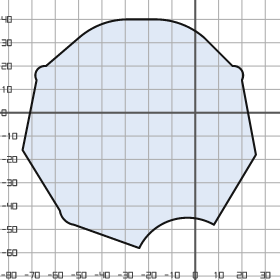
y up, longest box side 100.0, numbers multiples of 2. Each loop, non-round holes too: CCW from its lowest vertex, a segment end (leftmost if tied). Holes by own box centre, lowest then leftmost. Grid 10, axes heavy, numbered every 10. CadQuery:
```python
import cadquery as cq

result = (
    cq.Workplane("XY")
    .moveTo(-24.0, -58.0)
    .threePointArc((-10.0, -46.0), (8.0, -48.0))
    .lineTo(26.0, -18.0)
    .lineTo(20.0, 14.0)
    .threePointArc((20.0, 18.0), (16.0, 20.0))
    .lineTo(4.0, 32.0)
    .threePointArc((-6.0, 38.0), (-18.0, 40.0))
    .lineTo(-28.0, 40.0)
    .threePointArc((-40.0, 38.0), (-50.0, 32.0))
    .lineTo(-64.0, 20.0)
    .threePointArc((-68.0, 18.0), (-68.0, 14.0))
    .lineTo(-74.0, -16.0)
    .lineTo(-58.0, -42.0)
    .threePointArc((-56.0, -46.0), (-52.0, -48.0))
    .close()
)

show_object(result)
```